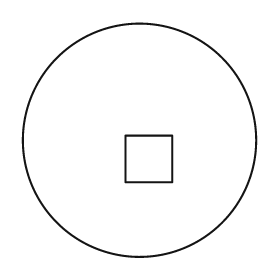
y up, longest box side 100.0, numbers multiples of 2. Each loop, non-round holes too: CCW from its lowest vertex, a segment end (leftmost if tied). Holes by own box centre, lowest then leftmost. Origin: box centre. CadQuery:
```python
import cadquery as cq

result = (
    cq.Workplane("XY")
    .moveTo(0.0, 0.0)
    .circle(50.0)
    .moveTo(-6.0, -18.0)
    .lineTo(14.0, -18.0)
    .lineTo(14.0, 2.0)
    .lineTo(-6.0, 2.0)
    .close()
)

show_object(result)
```